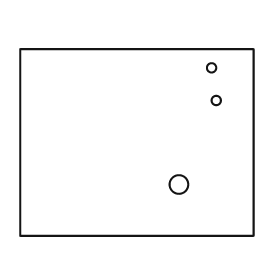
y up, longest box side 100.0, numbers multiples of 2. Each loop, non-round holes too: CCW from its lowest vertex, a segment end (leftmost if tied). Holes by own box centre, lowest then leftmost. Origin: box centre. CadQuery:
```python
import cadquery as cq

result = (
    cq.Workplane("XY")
    .moveTo(-50.0, -40.0)
    .lineTo(50.0, -40.0)
    .lineTo(50.0, 40.0)
    .lineTo(-50.0, 40.0)
    .close()
    .moveTo(18.0, -18.0)
    .circle(4.0)
    .moveTo(34.0, 18.0)
    .circle(2.0)
    .moveTo(32.0, 32.0)
    .circle(2.0)
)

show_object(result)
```